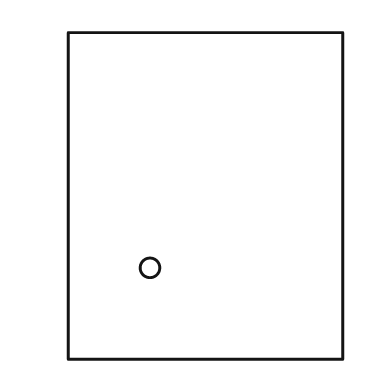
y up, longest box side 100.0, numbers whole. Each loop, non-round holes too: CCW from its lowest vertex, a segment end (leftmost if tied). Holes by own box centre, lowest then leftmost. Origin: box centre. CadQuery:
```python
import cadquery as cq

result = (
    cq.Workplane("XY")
    .moveTo(-42.0, -50.0)
    .lineTo(42.0, -50.0)
    .lineTo(42.0, 50.0)
    .lineTo(-42.0, 50.0)
    .close()
    .moveTo(-17.0, -22.0)
    .circle(3.0)
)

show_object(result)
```